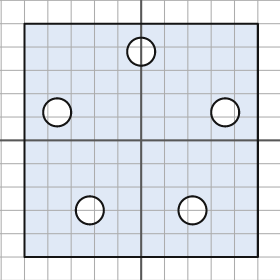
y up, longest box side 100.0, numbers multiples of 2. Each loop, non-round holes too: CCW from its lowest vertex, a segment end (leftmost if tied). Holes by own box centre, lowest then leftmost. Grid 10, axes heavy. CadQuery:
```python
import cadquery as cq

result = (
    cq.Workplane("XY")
    .moveTo(-50.0, -50.0)
    .lineTo(50.0, -50.0)
    .lineTo(50.0, 50.0)
    .lineTo(-50.0, 50.0)
    .close()
    .moveTo(-22.0, -30.0)
    .circle(6.0)
    .moveTo(22.0, -30.0)
    .circle(6.0)
    .moveTo(-36.0, 12.0)
    .circle(6.0)
    .moveTo(36.0, 12.0)
    .circle(6.0)
    .moveTo(0.0, 38.0)
    .circle(6.0)
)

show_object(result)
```